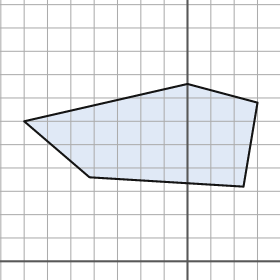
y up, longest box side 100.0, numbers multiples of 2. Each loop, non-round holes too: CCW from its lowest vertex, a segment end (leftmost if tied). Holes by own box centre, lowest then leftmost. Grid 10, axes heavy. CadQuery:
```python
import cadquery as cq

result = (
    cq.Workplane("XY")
    .moveTo(24.0, 32.0)
    .lineTo(30.0, 68.0)
    .lineTo(0.0, 76.0)
    .lineTo(-70.0, 60.0)
    .lineTo(-42.0, 36.0)
    .close()
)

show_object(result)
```